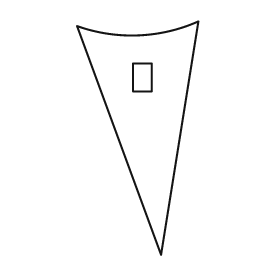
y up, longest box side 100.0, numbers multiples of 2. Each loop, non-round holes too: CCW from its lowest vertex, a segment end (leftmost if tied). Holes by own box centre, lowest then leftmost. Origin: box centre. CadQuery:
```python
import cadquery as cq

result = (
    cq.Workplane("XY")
    .moveTo(10.0, -50.0)
    .lineTo(26.0, 50.0)
    .threePointArc((0.0, 44.0), (-26.0, 48.0))
    .close()
    .moveTo(-2.0, 20.0)
    .lineTo(6.0, 20.0)
    .lineTo(6.0, 32.0)
    .lineTo(-2.0, 32.0)
    .close()
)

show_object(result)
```